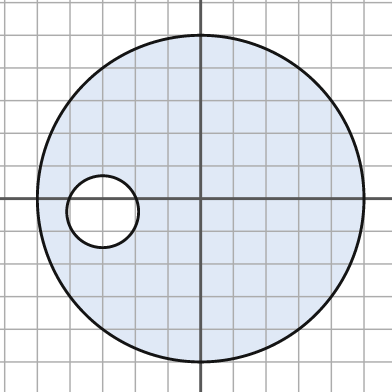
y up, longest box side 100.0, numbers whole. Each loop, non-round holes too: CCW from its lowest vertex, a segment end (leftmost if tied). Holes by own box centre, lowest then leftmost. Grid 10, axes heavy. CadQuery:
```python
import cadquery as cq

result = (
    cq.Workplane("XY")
    .moveTo(0.0, 0.0)
    .circle(50.0)
    .moveTo(-30.0, -4.0)
    .circle(11.0)
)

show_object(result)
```